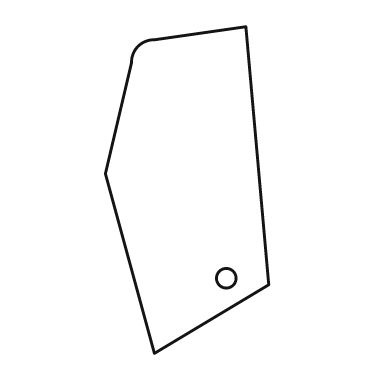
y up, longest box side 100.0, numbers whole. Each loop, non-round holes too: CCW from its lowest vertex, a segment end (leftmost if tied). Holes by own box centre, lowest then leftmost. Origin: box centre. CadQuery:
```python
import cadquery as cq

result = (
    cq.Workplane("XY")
    .moveTo(-10.0, -50.0)
    .lineTo(25.0, -29.0)
    .lineTo(18.0, 50.0)
    .lineTo(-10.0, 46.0)
    .threePointArc((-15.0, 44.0), (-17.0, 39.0))
    .lineTo(-25.0, 5.0)
    .close()
    .moveTo(12.0, -27.0)
    .circle(3.0)
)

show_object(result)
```